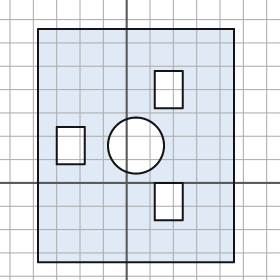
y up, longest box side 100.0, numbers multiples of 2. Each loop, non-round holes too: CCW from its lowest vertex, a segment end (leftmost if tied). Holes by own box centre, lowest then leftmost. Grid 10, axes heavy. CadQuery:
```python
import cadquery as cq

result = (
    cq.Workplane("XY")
    .moveTo(-38.0, -34.0)
    .lineTo(46.0, -34.0)
    .lineTo(46.0, 66.0)
    .lineTo(-38.0, 66.0)
    .close()
    .moveTo(12.0, -16.0)
    .lineTo(24.0, -16.0)
    .lineTo(24.0, 0.0)
    .lineTo(12.0, 0.0)
    .close()
    .moveTo(-30.0, 8.0)
    .lineTo(-18.0, 8.0)
    .lineTo(-18.0, 24.0)
    .lineTo(-30.0, 24.0)
    .close()
    .moveTo(4.0, 16.0)
    .circle(12.0)
    .moveTo(12.0, 32.0)
    .lineTo(24.0, 32.0)
    .lineTo(24.0, 48.0)
    .lineTo(12.0, 48.0)
    .close()
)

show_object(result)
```